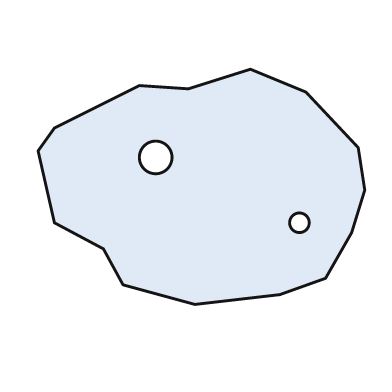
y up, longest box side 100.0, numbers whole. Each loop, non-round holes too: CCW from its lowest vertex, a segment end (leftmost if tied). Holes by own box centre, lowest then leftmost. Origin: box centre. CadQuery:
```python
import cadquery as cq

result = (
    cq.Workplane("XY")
    .moveTo(-2.0, -36.0)
    .lineTo(24.0, -33.0)
    .lineTo(38.0, -28.0)
    .lineTo(46.0, -14.0)
    .lineTo(50.0, -1.0)
    .lineTo(48.0, 12.0)
    .lineTo(32.0, 29.0)
    .lineTo(15.0, 36.0)
    .lineTo(-4.0, 30.0)
    .lineTo(-19.0, 31.0)
    .lineTo(-45.0, 18.0)
    .lineTo(-50.0, 11.0)
    .lineTo(-45.0, -11.0)
    .lineTo(-30.0, -19.0)
    .lineTo(-24.0, -30.0)
    .close()
    .moveTo(30.0, -11.0)
    .circle(3.0)
    .moveTo(-14.0, 9.0)
    .circle(5.0)
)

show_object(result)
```